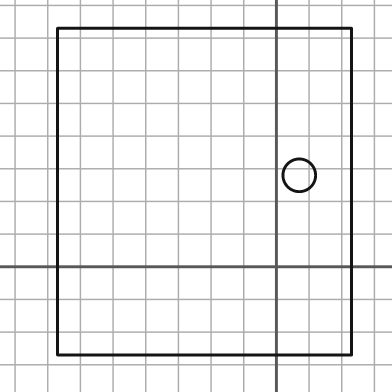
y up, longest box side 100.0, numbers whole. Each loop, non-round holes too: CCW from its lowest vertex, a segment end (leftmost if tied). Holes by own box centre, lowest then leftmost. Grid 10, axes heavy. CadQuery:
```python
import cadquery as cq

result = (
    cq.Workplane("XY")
    .moveTo(-67.0, -27.0)
    .lineTo(23.0, -27.0)
    .lineTo(23.0, 73.0)
    .lineTo(-67.0, 73.0)
    .close()
    .moveTo(7.0, 28.0)
    .circle(5.0)
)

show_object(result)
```